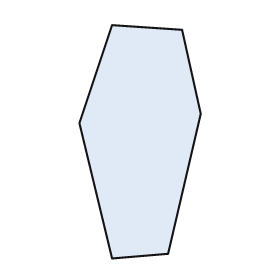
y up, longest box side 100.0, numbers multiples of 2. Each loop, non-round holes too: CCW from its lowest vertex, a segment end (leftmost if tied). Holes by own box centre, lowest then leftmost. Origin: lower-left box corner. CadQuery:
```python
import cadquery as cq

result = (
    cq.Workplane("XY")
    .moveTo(14.0, 0.0)
    .lineTo(38.0, 2.0)
    .lineTo(52.0, 62.0)
    .lineTo(44.0, 98.0)
    .lineTo(14.0, 100.0)
    .lineTo(0.0, 58.0)
    .close()
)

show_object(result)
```